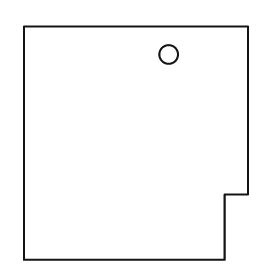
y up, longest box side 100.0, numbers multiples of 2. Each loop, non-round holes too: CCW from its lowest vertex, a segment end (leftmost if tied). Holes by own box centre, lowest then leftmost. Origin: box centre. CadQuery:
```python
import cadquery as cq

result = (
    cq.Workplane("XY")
    .moveTo(-48.0, -50.0)
    .lineTo(38.0, -50.0)
    .lineTo(38.0, -22.0)
    .lineTo(48.0, -22.0)
    .lineTo(48.0, 50.0)
    .lineTo(-48.0, 50.0)
    .close()
    .moveTo(14.0, 38.0)
    .circle(4.0)
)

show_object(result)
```